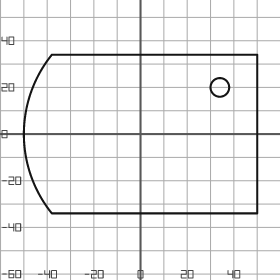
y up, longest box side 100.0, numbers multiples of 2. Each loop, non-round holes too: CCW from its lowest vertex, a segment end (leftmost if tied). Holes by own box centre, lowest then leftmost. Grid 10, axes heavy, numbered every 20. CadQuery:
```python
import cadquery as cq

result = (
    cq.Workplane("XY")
    .moveTo(-38.0, -34.0)
    .lineTo(50.0, -34.0)
    .lineTo(50.0, 34.0)
    .lineTo(-38.0, 34.0)
    .threePointArc((-50.0, 0.0), (-38.0, -34.0))
    .close()
    .moveTo(34.0, 20.0)
    .circle(4.0)
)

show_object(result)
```